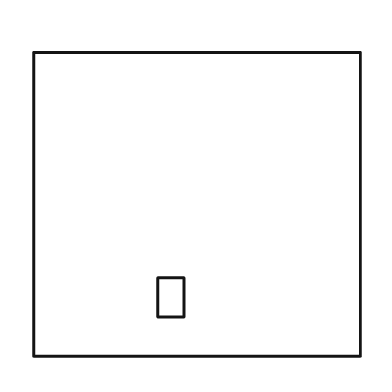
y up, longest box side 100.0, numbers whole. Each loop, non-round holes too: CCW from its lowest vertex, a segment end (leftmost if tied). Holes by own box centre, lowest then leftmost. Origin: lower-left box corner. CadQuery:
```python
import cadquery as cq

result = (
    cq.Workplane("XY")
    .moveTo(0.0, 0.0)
    .lineTo(100.0, 0.0)
    .lineTo(100.0, 93.0)
    .lineTo(0.0, 93.0)
    .close()
    .moveTo(38.0, 12.0)
    .lineTo(46.0, 12.0)
    .lineTo(46.0, 24.0)
    .lineTo(38.0, 24.0)
    .close()
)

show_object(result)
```